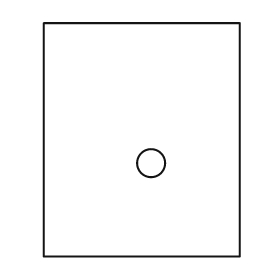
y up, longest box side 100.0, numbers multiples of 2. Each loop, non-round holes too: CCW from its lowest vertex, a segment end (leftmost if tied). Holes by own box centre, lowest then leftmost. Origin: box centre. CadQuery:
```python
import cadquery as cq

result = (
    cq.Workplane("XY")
    .moveTo(-42.0, -50.0)
    .lineTo(42.0, -50.0)
    .lineTo(42.0, 50.0)
    .lineTo(-42.0, 50.0)
    .close()
    .moveTo(4.0, -10.0)
    .circle(6.0)
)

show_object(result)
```